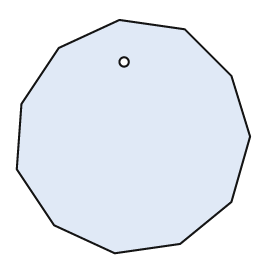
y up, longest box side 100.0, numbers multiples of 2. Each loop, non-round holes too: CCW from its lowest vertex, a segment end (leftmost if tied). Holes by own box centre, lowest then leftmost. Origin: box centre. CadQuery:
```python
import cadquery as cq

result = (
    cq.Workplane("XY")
    .moveTo(-8.0, -50.0)
    .lineTo(20.0, -46.0)
    .lineTo(42.0, -28.0)
    .lineTo(50.0, 0.0)
    .lineTo(42.0, 26.0)
    .lineTo(22.0, 46.0)
    .lineTo(-6.0, 50.0)
    .lineTo(-32.0, 38.0)
    .lineTo(-48.0, 14.0)
    .lineTo(-50.0, -14.0)
    .lineTo(-34.0, -38.0)
    .close()
    .moveTo(-4.0, 32.0)
    .circle(2.0)
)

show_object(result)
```